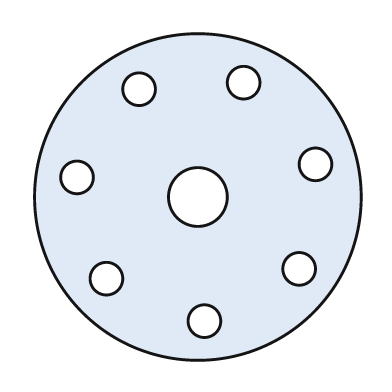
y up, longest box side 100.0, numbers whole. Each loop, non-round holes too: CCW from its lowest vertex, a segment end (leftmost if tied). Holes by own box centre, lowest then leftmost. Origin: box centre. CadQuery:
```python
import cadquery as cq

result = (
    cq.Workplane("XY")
    .moveTo(0.0, 0.0)
    .circle(50.0)
    .moveTo(2.0, -38.0)
    .circle(5.0)
    .moveTo(-28.0, -25.0)
    .circle(5.0)
    .moveTo(31.0, -22.0)
    .circle(5.0)
    .moveTo(0.0, 0.0)
    .circle(9.0)
    .moveTo(-37.0, 6.0)
    .circle(5.0)
    .moveTo(36.0, 10.0)
    .circle(5.0)
    .moveTo(-18.0, 33.0)
    .circle(5.0)
    .moveTo(14.0, 35.0)
    .circle(5.0)
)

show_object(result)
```